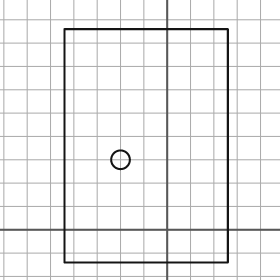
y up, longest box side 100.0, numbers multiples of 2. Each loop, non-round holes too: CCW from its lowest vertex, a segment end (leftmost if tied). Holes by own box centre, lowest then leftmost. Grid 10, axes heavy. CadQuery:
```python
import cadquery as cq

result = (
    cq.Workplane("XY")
    .moveTo(-44.0, -14.0)
    .lineTo(26.0, -14.0)
    .lineTo(26.0, 86.0)
    .lineTo(-44.0, 86.0)
    .close()
    .moveTo(-20.0, 30.0)
    .circle(4.0)
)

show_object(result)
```